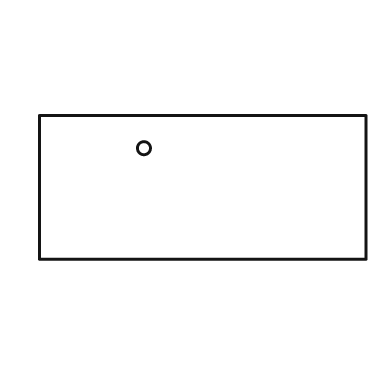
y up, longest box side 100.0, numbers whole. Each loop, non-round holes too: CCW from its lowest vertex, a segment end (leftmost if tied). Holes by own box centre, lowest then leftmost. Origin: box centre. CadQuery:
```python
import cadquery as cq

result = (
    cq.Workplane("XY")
    .moveTo(-50.0, -22.0)
    .lineTo(50.0, -22.0)
    .lineTo(50.0, 22.0)
    .lineTo(-50.0, 22.0)
    .close()
    .moveTo(-18.0, 12.0)
    .circle(2.0)
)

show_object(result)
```